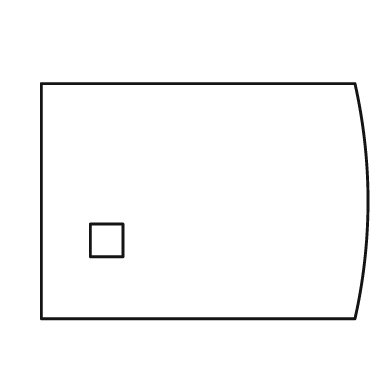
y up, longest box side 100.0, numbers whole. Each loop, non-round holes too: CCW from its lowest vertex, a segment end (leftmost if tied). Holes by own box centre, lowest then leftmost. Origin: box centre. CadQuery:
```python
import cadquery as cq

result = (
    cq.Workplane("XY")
    .moveTo(-50.0, -36.0)
    .lineTo(46.0, -36.0)
    .threePointArc((50.0, 0.0), (46.0, 36.0))
    .lineTo(-50.0, 36.0)
    .close()
    .moveTo(-35.0, -17.0)
    .lineTo(-25.0, -17.0)
    .lineTo(-25.0, -7.0)
    .lineTo(-35.0, -7.0)
    .close()
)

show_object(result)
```